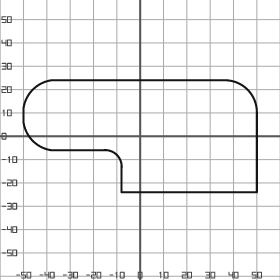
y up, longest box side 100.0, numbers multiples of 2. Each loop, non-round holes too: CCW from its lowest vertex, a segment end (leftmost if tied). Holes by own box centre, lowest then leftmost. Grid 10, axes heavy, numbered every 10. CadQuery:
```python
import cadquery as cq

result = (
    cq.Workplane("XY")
    .moveTo(-8.0, -24.0)
    .lineTo(50.0, -24.0)
    .lineTo(50.0, 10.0)
    .threePointArc((46.0, 20.0), (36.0, 24.0))
    .lineTo(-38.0, 24.0)
    .threePointArc((-46.0, 20.0), (-50.0, 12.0))
    .lineTo(-50.0, 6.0)
    .threePointArc((-46.0, -2.0), (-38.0, -6.0))
    .lineTo(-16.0, -6.0)
    .threePointArc((-10.0, -8.0), (-8.0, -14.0))
    .close()
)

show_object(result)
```